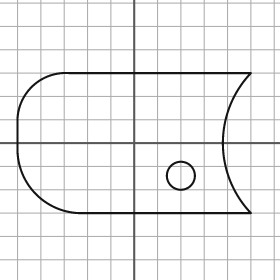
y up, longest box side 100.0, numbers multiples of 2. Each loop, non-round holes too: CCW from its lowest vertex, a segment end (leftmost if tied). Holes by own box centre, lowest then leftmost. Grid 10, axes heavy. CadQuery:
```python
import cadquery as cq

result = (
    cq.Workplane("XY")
    .moveTo(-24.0, -30.0)
    .lineTo(50.0, -30.0)
    .threePointArc((38.0, 0.0), (50.0, 30.0))
    .lineTo(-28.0, 30.0)
    .threePointArc((-44.0, 24.0), (-50.0, 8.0))
    .lineTo(-50.0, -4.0)
    .threePointArc((-42.0, -22.0), (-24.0, -30.0))
    .close()
    .moveTo(20.0, -14.0)
    .circle(6.0)
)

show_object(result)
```